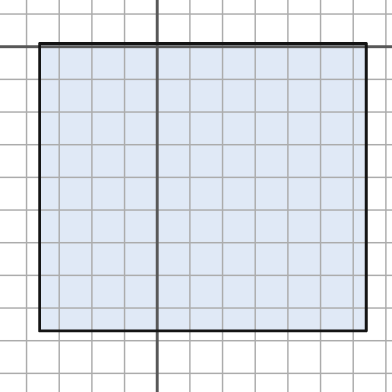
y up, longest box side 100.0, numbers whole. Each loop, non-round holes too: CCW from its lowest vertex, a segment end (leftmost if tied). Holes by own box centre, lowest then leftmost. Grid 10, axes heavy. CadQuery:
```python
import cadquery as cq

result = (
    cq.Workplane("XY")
    .moveTo(-36.0, -87.0)
    .lineTo(64.0, -87.0)
    .lineTo(64.0, 1.0)
    .lineTo(-36.0, 1.0)
    .close()
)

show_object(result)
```